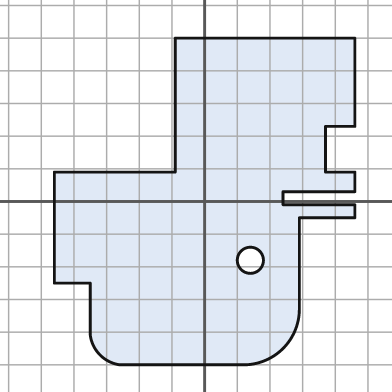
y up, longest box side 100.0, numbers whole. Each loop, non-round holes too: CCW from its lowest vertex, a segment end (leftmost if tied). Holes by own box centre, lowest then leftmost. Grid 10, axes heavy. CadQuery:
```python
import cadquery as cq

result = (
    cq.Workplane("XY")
    .moveTo(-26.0, -50.0)
    .lineTo(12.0, -50.0)
    .threePointArc((24.0, -45.0), (29.0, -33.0))
    .lineTo(29.0, -5.0)
    .lineTo(46.0, -5.0)
    .lineTo(46.0, -1.0)
    .lineTo(24.0, -1.0)
    .lineTo(24.0, 3.0)
    .lineTo(46.0, 3.0)
    .lineTo(46.0, 9.0)
    .lineTo(37.0, 9.0)
    .lineTo(37.0, 23.0)
    .lineTo(46.0, 23.0)
    .lineTo(46.0, 50.0)
    .lineTo(-9.0, 50.0)
    .lineTo(-9.0, 9.0)
    .lineTo(-46.0, 9.0)
    .lineTo(-46.0, -25.0)
    .lineTo(-35.0, -25.0)
    .lineTo(-35.0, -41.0)
    .threePointArc((-32.0, -47.0), (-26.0, -50.0))
    .close()
    .moveTo(14.0, -18.0)
    .circle(4.0)
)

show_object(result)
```